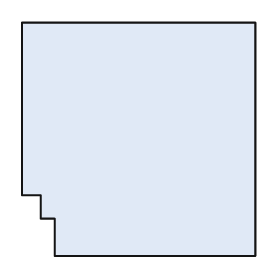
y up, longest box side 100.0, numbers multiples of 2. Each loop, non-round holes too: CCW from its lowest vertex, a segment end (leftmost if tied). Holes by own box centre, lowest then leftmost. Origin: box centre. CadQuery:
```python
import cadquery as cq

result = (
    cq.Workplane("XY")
    .moveTo(-36.0, -50.0)
    .lineTo(50.0, -50.0)
    .lineTo(50.0, 50.0)
    .lineTo(-50.0, 50.0)
    .lineTo(-50.0, -24.0)
    .lineTo(-42.0, -24.0)
    .lineTo(-42.0, -34.0)
    .lineTo(-36.0, -34.0)
    .close()
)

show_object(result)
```